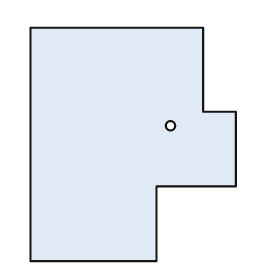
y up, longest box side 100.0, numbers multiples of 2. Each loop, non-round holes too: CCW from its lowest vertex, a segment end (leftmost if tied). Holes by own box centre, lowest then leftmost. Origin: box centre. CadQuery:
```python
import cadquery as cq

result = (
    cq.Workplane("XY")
    .moveTo(-44.0, -50.0)
    .lineTo(10.0, -50.0)
    .lineTo(10.0, -18.0)
    .lineTo(44.0, -18.0)
    .lineTo(44.0, 14.0)
    .lineTo(30.0, 14.0)
    .lineTo(30.0, 50.0)
    .lineTo(-44.0, 50.0)
    .close()
    .moveTo(16.0, 8.0)
    .circle(2.0)
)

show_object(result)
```